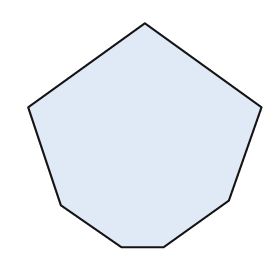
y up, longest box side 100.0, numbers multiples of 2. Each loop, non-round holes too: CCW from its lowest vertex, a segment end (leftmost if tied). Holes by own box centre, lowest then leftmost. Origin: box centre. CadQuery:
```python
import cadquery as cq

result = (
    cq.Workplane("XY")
    .moveTo(-10.0, -48.0)
    .lineTo(8.0, -48.0)
    .lineTo(36.0, -28.0)
    .lineTo(50.0, 12.0)
    .lineTo(0.0, 48.0)
    .lineTo(-50.0, 12.0)
    .lineTo(-36.0, -30.0)
    .close()
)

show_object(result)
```